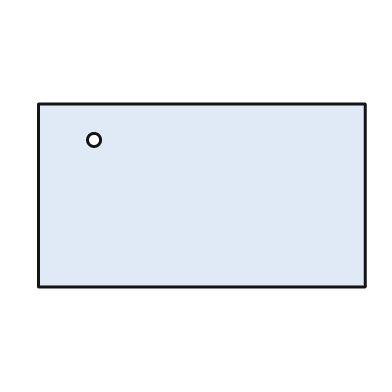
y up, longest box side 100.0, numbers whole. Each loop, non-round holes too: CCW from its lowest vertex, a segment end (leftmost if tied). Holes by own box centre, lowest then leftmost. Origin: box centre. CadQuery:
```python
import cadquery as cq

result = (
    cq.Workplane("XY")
    .moveTo(-50.0, -28.0)
    .lineTo(50.0, -28.0)
    .lineTo(50.0, 28.0)
    .lineTo(-50.0, 28.0)
    .close()
    .moveTo(-33.0, 17.0)
    .circle(2.0)
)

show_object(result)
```